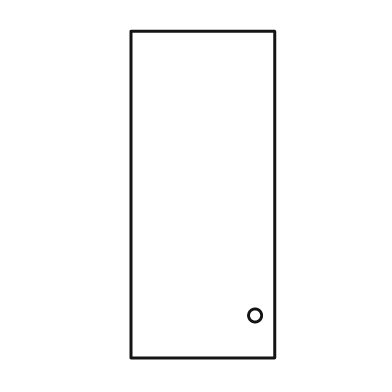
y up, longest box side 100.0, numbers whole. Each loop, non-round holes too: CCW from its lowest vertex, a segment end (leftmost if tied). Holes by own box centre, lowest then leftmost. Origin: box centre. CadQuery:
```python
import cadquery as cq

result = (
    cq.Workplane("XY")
    .moveTo(-22.0, -50.0)
    .lineTo(22.0, -50.0)
    .lineTo(22.0, 50.0)
    .lineTo(-22.0, 50.0)
    .close()
    .moveTo(16.0, -37.0)
    .circle(2.0)
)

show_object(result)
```